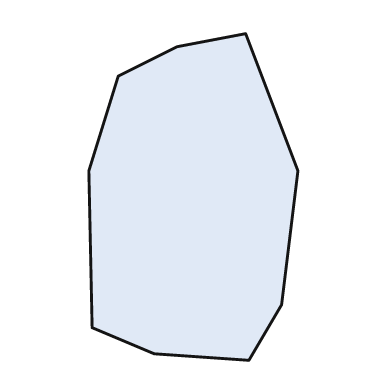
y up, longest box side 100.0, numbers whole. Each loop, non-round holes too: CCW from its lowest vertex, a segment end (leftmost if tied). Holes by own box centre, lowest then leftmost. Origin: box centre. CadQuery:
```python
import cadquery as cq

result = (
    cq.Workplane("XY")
    .moveTo(17.0, -50.0)
    .lineTo(27.0, -33.0)
    .lineTo(32.0, 8.0)
    .lineTo(16.0, 50.0)
    .lineTo(-5.0, 46.0)
    .lineTo(-23.0, 37.0)
    .lineTo(-32.0, 8.0)
    .lineTo(-31.0, -40.0)
    .lineTo(-12.0, -48.0)
    .close()
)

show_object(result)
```